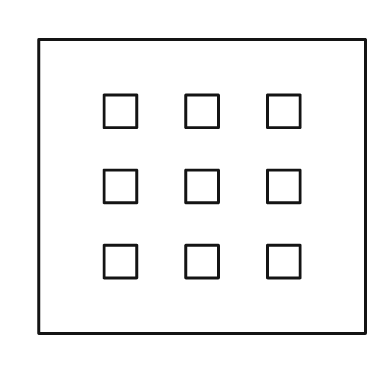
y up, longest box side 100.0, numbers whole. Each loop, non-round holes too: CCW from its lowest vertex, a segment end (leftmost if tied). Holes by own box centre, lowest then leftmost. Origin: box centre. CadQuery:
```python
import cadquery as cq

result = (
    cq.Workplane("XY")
    .moveTo(-50.0, -45.0)
    .lineTo(50.0, -45.0)
    .lineTo(50.0, 45.0)
    .lineTo(-50.0, 45.0)
    .close()
    .moveTo(-30.0, -28.0)
    .lineTo(-20.0, -28.0)
    .lineTo(-20.0, -18.0)
    .lineTo(-30.0, -18.0)
    .close()
    .moveTo(-5.0, -28.0)
    .lineTo(5.0, -28.0)
    .lineTo(5.0, -18.0)
    .lineTo(-5.0, -18.0)
    .close()
    .moveTo(20.0, -28.0)
    .lineTo(30.0, -28.0)
    .lineTo(30.0, -18.0)
    .lineTo(20.0, -18.0)
    .close()
    .moveTo(-30.0, -5.0)
    .lineTo(-20.0, -5.0)
    .lineTo(-20.0, 5.0)
    .lineTo(-30.0, 5.0)
    .close()
    .moveTo(-5.0, -5.0)
    .lineTo(5.0, -5.0)
    .lineTo(5.0, 5.0)
    .lineTo(-5.0, 5.0)
    .close()
    .moveTo(20.0, -5.0)
    .lineTo(30.0, -5.0)
    .lineTo(30.0, 5.0)
    .lineTo(20.0, 5.0)
    .close()
    .moveTo(-30.0, 18.0)
    .lineTo(-20.0, 18.0)
    .lineTo(-20.0, 28.0)
    .lineTo(-30.0, 28.0)
    .close()
    .moveTo(-5.0, 18.0)
    .lineTo(5.0, 18.0)
    .lineTo(5.0, 28.0)
    .lineTo(-5.0, 28.0)
    .close()
    .moveTo(20.0, 18.0)
    .lineTo(30.0, 18.0)
    .lineTo(30.0, 28.0)
    .lineTo(20.0, 28.0)
    .close()
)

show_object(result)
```